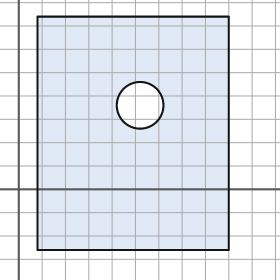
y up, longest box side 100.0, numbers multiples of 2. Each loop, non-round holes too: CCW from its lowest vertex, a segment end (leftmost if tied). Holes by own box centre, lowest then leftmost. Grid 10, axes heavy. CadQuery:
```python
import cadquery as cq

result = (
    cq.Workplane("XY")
    .moveTo(8.0, -26.0)
    .lineTo(90.0, -26.0)
    .lineTo(90.0, 74.0)
    .lineTo(8.0, 74.0)
    .close()
    .moveTo(52.0, 36.0)
    .circle(10.0)
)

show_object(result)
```